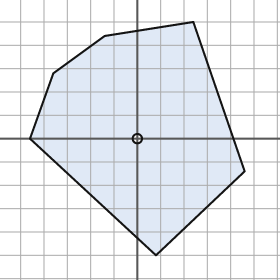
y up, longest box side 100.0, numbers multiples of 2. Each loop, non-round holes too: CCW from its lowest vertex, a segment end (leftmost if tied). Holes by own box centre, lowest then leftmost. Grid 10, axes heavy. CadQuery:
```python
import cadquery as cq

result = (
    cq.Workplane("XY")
    .moveTo(8.0, -50.0)
    .lineTo(46.0, -14.0)
    .lineTo(24.0, 50.0)
    .lineTo(-14.0, 44.0)
    .lineTo(-36.0, 28.0)
    .lineTo(-46.0, 0.0)
    .close()
    .moveTo(0.0, 0.0)
    .circle(2.0)
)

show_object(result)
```